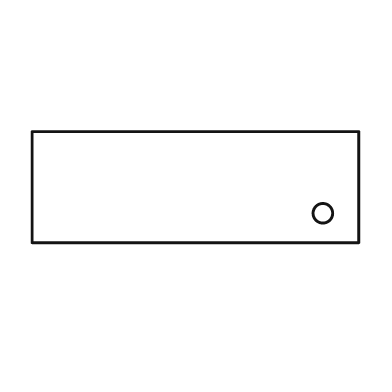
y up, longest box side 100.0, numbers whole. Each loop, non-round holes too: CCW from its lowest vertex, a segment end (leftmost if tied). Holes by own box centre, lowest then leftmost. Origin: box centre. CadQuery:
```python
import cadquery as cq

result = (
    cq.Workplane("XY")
    .moveTo(-50.0, -17.0)
    .lineTo(50.0, -17.0)
    .lineTo(50.0, 17.0)
    .lineTo(-50.0, 17.0)
    .close()
    .moveTo(39.0, -8.0)
    .circle(3.0)
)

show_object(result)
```